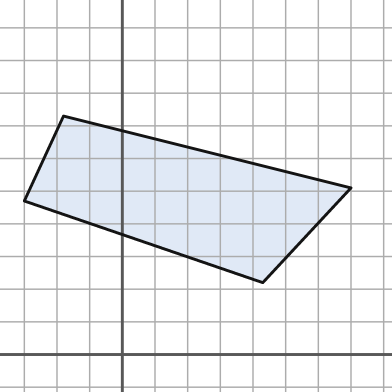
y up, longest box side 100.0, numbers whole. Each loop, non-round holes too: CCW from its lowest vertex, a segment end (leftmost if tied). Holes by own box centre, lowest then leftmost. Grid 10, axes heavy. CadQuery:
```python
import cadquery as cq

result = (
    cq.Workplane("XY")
    .moveTo(43.0, 22.0)
    .lineTo(70.0, 51.0)
    .lineTo(-18.0, 73.0)
    .lineTo(-30.0, 47.0)
    .close()
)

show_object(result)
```